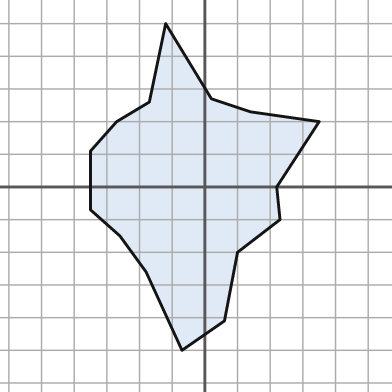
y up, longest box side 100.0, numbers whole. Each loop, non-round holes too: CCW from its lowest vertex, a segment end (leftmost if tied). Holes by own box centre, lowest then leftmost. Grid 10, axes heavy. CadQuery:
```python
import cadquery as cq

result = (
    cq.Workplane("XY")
    .moveTo(-7.0, -50.0)
    .lineTo(6.0, -41.0)
    .lineTo(10.0, -20.0)
    .lineTo(23.0, -10.0)
    .lineTo(22.0, 0.0)
    .lineTo(35.0, 20.0)
    .lineTo(14.0, 23.0)
    .lineTo(2.0, 27.0)
    .lineTo(-12.0, 50.0)
    .lineTo(-17.0, 26.0)
    .lineTo(-27.0, 20.0)
    .lineTo(-35.0, 11.0)
    .lineTo(-35.0, -7.0)
    .lineTo(-26.0, -15.0)
    .lineTo(-18.0, -26.0)
    .close()
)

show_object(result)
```